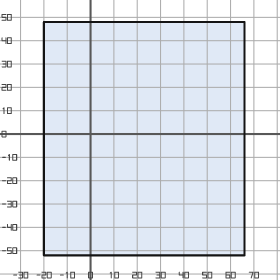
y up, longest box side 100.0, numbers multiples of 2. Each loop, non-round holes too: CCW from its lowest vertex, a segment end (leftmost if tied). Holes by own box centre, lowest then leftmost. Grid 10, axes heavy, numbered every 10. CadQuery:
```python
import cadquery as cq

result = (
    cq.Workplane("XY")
    .moveTo(-20.0, -52.0)
    .lineTo(66.0, -52.0)
    .lineTo(66.0, 48.0)
    .lineTo(-20.0, 48.0)
    .close()
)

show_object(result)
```